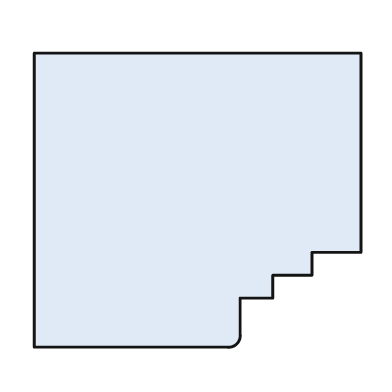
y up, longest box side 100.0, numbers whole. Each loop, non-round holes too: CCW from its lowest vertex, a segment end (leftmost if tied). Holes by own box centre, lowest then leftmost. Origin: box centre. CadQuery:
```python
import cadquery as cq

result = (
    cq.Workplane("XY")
    .moveTo(-50.0, -45.0)
    .lineTo(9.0, -45.0)
    .threePointArc((12.0, -44.0), (13.0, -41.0))
    .lineTo(13.0, -30.0)
    .lineTo(23.0, -30.0)
    .lineTo(23.0, -23.0)
    .lineTo(35.0, -23.0)
    .lineTo(35.0, -16.0)
    .lineTo(50.0, -16.0)
    .lineTo(50.0, 45.0)
    .lineTo(-50.0, 45.0)
    .close()
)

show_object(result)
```